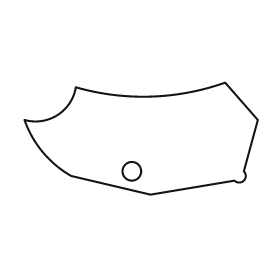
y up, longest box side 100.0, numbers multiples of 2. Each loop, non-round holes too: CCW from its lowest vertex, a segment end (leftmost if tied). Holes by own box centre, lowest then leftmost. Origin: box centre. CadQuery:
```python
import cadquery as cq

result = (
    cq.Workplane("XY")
    .moveTo(4.0, -24.0)
    .lineTo(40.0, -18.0)
    .threePointArc((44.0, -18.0), (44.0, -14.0))
    .lineTo(50.0, 8.0)
    .lineTo(36.0, 24.0)
    .threePointArc((4.0, 18.0), (-28.0, 22.0))
    .threePointArc((-36.0, 10.0), (-50.0, 8.0))
    .threePointArc((-42.0, -6.0), (-30.0, -16.0))
    .close()
    .moveTo(-4.0, -14.0)
    .circle(4.0)
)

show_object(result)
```